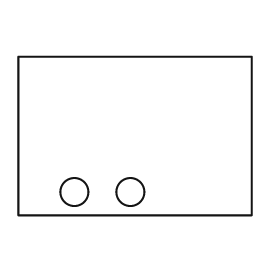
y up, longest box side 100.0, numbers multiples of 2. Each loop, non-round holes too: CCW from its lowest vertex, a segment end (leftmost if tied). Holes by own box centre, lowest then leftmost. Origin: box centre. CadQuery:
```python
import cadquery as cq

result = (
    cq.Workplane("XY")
    .moveTo(-50.0, -34.0)
    .lineTo(50.0, -34.0)
    .lineTo(50.0, 34.0)
    .lineTo(-50.0, 34.0)
    .close()
    .moveTo(-26.0, -24.0)
    .circle(6.0)
    .moveTo(-2.0, -24.0)
    .circle(6.0)
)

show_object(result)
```